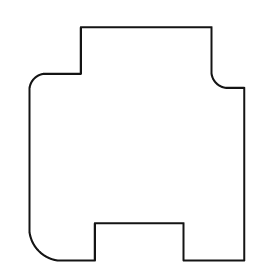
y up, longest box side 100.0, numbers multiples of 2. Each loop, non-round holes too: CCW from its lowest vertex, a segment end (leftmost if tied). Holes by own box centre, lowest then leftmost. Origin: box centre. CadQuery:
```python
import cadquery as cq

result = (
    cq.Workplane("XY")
    .moveTo(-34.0, -50.0)
    .lineTo(-18.0, -50.0)
    .lineTo(-18.0, -34.0)
    .lineTo(20.0, -34.0)
    .lineTo(20.0, -50.0)
    .lineTo(46.0, -50.0)
    .lineTo(46.0, 24.0)
    .lineTo(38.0, 24.0)
    .threePointArc((34.0, 26.0), (32.0, 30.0))
    .lineTo(32.0, 50.0)
    .lineTo(-24.0, 50.0)
    .lineTo(-24.0, 30.0)
    .lineTo(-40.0, 30.0)
    .threePointArc((-44.0, 28.0), (-46.0, 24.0))
    .lineTo(-46.0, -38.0)
    .threePointArc((-42.0, -46.0), (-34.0, -50.0))
    .close()
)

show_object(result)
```